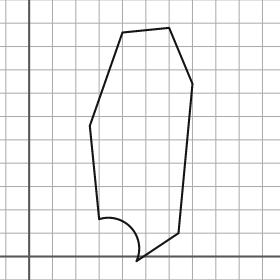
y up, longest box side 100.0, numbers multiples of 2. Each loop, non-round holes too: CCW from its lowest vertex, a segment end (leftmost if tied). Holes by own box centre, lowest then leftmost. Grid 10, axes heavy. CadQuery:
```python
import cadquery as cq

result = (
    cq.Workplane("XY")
    .moveTo(46.0, -2.0)
    .lineTo(64.0, 10.0)
    .lineTo(70.0, 74.0)
    .lineTo(60.0, 98.0)
    .lineTo(40.0, 96.0)
    .lineTo(26.0, 56.0)
    .lineTo(30.0, 16.0)
    .threePointArc((44.0, 12.0), (46.0, -2.0))
    .close()
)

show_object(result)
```